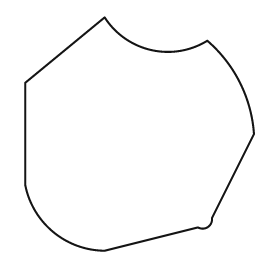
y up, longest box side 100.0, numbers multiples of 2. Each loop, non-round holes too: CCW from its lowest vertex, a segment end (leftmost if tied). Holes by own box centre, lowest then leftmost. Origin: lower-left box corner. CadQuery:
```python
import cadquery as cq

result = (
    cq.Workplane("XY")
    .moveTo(34.0, 0.0)
    .lineTo(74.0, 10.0)
    .threePointArc((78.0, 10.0), (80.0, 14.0))
    .lineTo(98.0, 50.0)
    .threePointArc((92.0, 72.0), (78.0, 90.0))
    .threePointArc((54.0, 86.0), (34.0, 100.0))
    .lineTo(0.0, 72.0)
    .lineTo(0.0, 28.0)
    .threePointArc((12.0, 8.0), (34.0, 0.0))
    .close()
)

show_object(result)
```